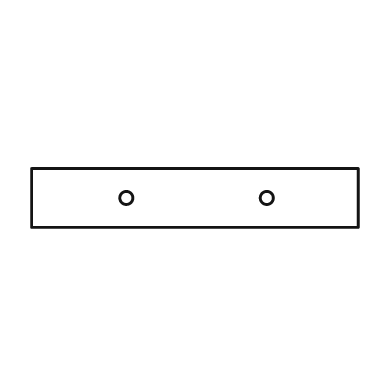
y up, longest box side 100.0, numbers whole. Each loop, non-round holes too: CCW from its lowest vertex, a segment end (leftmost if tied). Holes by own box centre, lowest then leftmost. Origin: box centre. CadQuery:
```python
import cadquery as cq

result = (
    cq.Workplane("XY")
    .moveTo(-50.0, -9.0)
    .lineTo(50.0, -9.0)
    .lineTo(50.0, 9.0)
    .lineTo(-50.0, 9.0)
    .close()
    .moveTo(-21.0, 0.0)
    .circle(2.0)
    .moveTo(22.0, 0.0)
    .circle(2.0)
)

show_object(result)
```